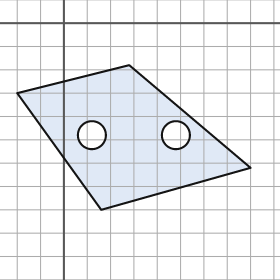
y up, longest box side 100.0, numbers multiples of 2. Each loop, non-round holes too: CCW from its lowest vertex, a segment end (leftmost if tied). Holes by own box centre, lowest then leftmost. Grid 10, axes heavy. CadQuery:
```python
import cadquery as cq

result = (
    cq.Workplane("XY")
    .moveTo(16.0, -80.0)
    .lineTo(80.0, -62.0)
    .lineTo(28.0, -18.0)
    .lineTo(-20.0, -30.0)
    .close()
    .moveTo(12.0, -48.0)
    .circle(6.0)
    .moveTo(48.0, -48.0)
    .circle(6.0)
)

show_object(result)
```